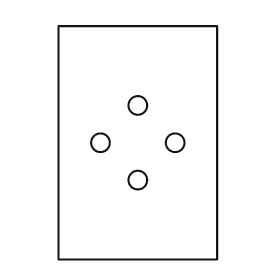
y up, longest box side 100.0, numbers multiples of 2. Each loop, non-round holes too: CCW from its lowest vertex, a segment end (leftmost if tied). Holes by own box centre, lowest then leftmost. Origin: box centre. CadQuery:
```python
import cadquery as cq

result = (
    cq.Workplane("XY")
    .moveTo(-34.0, -50.0)
    .lineTo(34.0, -50.0)
    .lineTo(34.0, 50.0)
    .lineTo(-34.0, 50.0)
    .close()
    .moveTo(0.0, -16.0)
    .circle(4.0)
    .moveTo(-16.0, 0.0)
    .circle(4.0)
    .moveTo(16.0, 0.0)
    .circle(4.0)
    .moveTo(0.0, 16.0)
    .circle(4.0)
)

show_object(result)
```